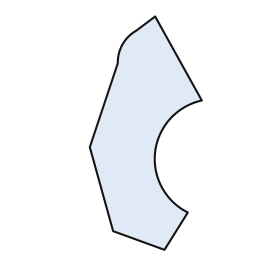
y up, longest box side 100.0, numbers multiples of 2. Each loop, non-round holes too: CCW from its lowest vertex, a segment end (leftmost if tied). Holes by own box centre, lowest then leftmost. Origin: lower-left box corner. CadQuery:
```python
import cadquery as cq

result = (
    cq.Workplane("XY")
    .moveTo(32.0, 0.0)
    .lineTo(42.0, 16.0)
    .threePointArc((28.0, 42.0), (48.0, 64.0))
    .lineTo(28.0, 100.0)
    .lineTo(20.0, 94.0)
    .threePointArc((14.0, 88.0), (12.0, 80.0))
    .lineTo(0.0, 44.0)
    .lineTo(10.0, 8.0)
    .close()
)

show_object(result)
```